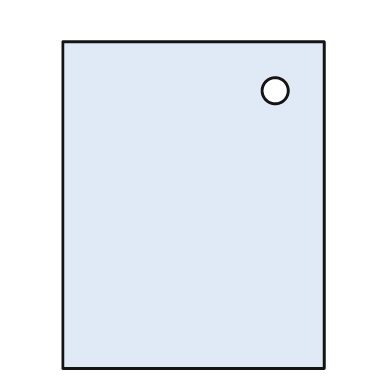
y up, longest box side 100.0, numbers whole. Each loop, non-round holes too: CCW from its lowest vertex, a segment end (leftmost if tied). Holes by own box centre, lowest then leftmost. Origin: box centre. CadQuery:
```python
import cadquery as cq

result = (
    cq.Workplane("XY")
    .moveTo(-40.0, -50.0)
    .lineTo(40.0, -50.0)
    .lineTo(40.0, 50.0)
    .lineTo(-40.0, 50.0)
    .close()
    .moveTo(25.0, 35.0)
    .circle(4.0)
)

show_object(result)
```